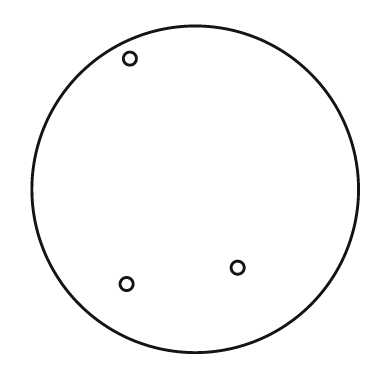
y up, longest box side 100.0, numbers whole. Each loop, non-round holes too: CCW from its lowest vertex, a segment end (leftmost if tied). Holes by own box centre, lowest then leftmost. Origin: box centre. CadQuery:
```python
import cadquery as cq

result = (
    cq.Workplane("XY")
    .moveTo(0.0, 0.0)
    .circle(50.0)
    .moveTo(-21.0, -29.0)
    .circle(2.0)
    .moveTo(13.0, -24.0)
    .circle(2.0)
    .moveTo(-20.0, 40.0)
    .circle(2.0)
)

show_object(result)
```